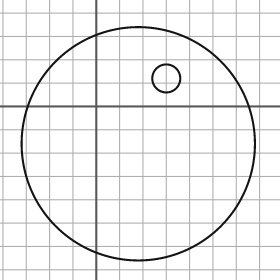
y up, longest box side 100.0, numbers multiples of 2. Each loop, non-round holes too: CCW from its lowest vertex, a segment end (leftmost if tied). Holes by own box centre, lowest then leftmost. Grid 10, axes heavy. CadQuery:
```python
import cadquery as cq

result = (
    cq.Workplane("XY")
    .moveTo(18.0, -16.0)
    .circle(50.0)
    .moveTo(30.0, 12.0)
    .circle(6.0)
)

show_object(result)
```